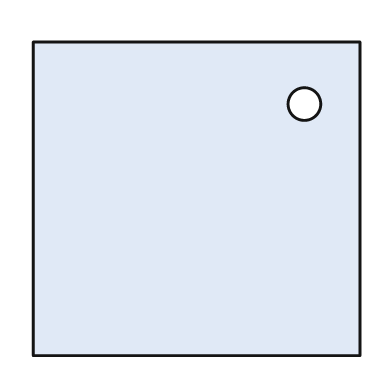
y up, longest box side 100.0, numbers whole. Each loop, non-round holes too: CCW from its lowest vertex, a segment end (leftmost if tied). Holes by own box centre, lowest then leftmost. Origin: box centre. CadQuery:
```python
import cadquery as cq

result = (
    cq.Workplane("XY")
    .moveTo(-50.0, -48.0)
    .lineTo(50.0, -48.0)
    .lineTo(50.0, 48.0)
    .lineTo(-50.0, 48.0)
    .close()
    .moveTo(33.0, 29.0)
    .circle(5.0)
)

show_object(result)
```